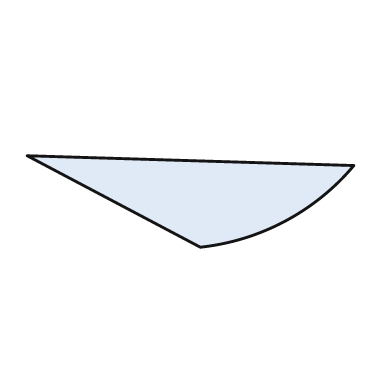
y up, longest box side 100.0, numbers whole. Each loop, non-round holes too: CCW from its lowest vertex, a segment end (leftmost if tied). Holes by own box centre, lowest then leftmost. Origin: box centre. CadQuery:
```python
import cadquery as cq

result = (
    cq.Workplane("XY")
    .moveTo(3.0, -14.0)
    .threePointArc((29.0, -6.0), (50.0, 11.0))
    .lineTo(-50.0, 14.0)
    .close()
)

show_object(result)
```